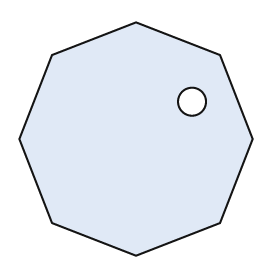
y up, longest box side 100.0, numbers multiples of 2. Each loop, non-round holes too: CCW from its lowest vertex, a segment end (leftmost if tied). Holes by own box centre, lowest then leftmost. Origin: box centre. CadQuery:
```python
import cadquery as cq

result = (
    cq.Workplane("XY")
    .moveTo(0.0, -50.0)
    .lineTo(36.0, -36.0)
    .lineTo(50.0, 0.0)
    .lineTo(36.0, 36.0)
    .lineTo(0.0, 50.0)
    .lineTo(-36.0, 36.0)
    .lineTo(-50.0, 0.0)
    .lineTo(-36.0, -36.0)
    .close()
    .moveTo(24.0, 16.0)
    .circle(6.0)
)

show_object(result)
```